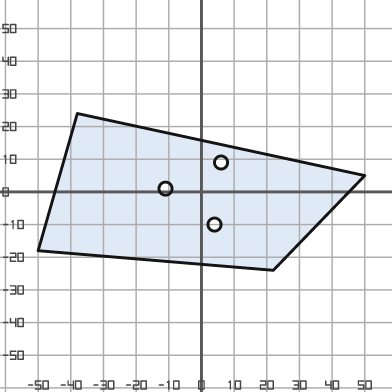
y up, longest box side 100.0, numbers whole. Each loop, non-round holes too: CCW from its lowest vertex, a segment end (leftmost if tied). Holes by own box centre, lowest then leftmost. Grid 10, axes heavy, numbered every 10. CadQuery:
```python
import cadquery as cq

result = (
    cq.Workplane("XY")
    .moveTo(22.0, -24.0)
    .lineTo(50.0, 5.0)
    .lineTo(-38.0, 24.0)
    .lineTo(-50.0, -18.0)
    .close()
    .moveTo(4.0, -10.0)
    .circle(2.0)
    .moveTo(-11.0, 1.0)
    .circle(2.0)
    .moveTo(6.0, 9.0)
    .circle(2.0)
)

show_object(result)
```